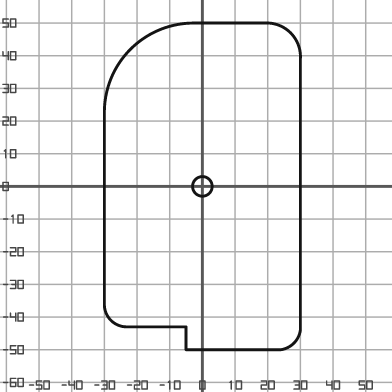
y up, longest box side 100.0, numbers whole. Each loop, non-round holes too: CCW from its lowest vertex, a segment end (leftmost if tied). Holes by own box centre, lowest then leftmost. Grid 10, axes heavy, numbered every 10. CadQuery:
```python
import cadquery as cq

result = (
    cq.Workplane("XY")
    .moveTo(-5.0, -50.0)
    .lineTo(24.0, -50.0)
    .threePointArc((28.0, -48.0), (30.0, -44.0))
    .lineTo(30.0, 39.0)
    .threePointArc((27.0, 47.0), (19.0, 50.0))
    .lineTo(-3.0, 50.0)
    .threePointArc((-22.0, 42.0), (-30.0, 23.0))
    .lineTo(-30.0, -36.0)
    .threePointArc((-28.0, -41.0), (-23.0, -43.0))
    .lineTo(-5.0, -43.0)
    .close()
    .moveTo(0.0, 0.0)
    .circle(3.0)
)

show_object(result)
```